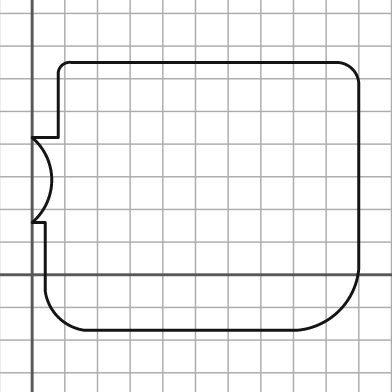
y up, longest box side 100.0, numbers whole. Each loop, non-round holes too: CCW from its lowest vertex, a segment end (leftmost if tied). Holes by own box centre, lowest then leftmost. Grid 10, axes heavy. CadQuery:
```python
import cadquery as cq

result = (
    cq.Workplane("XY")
    .moveTo(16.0, -17.0)
    .lineTo(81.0, -17.0)
    .threePointArc((94.0, -11.0), (100.0, 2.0))
    .lineTo(100.0, 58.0)
    .threePointArc((98.0, 63.0), (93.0, 65.0))
    .lineTo(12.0, 65.0)
    .threePointArc((9.0, 64.0), (8.0, 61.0))
    .lineTo(8.0, 42.0)
    .lineTo(0.0, 42.0)
    .threePointArc((6.0, 29.0), (0.0, 16.0))
    .lineTo(4.0, 16.0)
    .lineTo(4.0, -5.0)
    .threePointArc((8.0, -13.0), (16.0, -17.0))
    .close()
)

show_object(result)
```